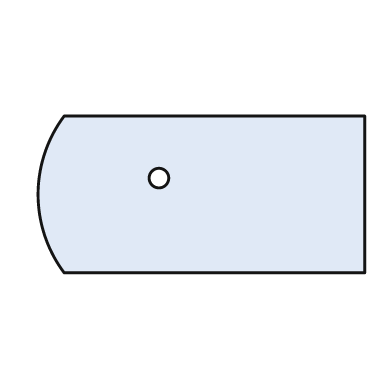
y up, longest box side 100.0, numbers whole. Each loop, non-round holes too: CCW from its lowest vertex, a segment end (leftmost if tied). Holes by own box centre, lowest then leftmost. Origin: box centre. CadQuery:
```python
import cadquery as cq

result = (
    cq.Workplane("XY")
    .moveTo(-42.0, -24.0)
    .lineTo(50.0, -24.0)
    .lineTo(50.0, 24.0)
    .lineTo(-42.0, 24.0)
    .threePointArc((-50.0, 0.0), (-42.0, -24.0))
    .close()
    .moveTo(-13.0, 5.0)
    .circle(3.0)
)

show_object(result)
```